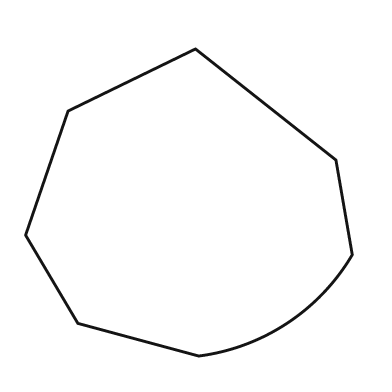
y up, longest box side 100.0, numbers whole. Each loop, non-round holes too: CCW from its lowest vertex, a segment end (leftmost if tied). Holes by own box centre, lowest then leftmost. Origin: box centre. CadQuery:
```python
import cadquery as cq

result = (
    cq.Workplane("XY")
    .moveTo(3.0, -47.0)
    .threePointArc((30.0, -37.0), (50.0, -16.0))
    .lineTo(45.0, 13.0)
    .lineTo(2.0, 47.0)
    .lineTo(-37.0, 28.0)
    .lineTo(-50.0, -10.0)
    .lineTo(-34.0, -37.0)
    .close()
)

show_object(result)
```